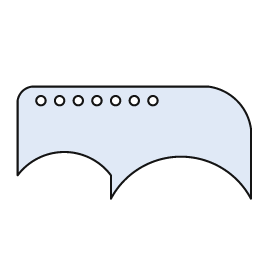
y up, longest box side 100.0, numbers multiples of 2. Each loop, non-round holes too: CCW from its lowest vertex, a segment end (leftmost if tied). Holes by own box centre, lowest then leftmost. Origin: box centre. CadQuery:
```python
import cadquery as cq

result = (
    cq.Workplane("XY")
    .moveTo(-10.0, -24.0)
    .threePointArc((20.0, -6.0), (50.0, -24.0))
    .lineTo(50.0, 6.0)
    .threePointArc((44.0, 18.0), (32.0, 24.0))
    .lineTo(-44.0, 24.0)
    .threePointArc((-48.0, 22.0), (-50.0, 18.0))
    .lineTo(-50.0, -14.0)
    .threePointArc((-30.0, -4.0), (-10.0, -14.0))
    .close()
    .moveTo(-40.0, 18.0)
    .circle(2.0)
    .moveTo(-32.0, 18.0)
    .circle(2.0)
    .moveTo(-24.0, 18.0)
    .circle(2.0)
    .moveTo(-16.0, 18.0)
    .circle(2.0)
    .moveTo(-8.0, 18.0)
    .circle(2.0)
    .moveTo(0.0, 18.0)
    .circle(2.0)
    .moveTo(8.0, 18.0)
    .circle(2.0)
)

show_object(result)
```